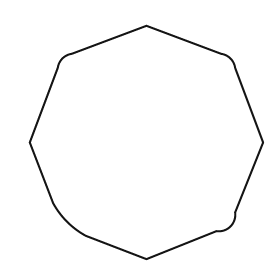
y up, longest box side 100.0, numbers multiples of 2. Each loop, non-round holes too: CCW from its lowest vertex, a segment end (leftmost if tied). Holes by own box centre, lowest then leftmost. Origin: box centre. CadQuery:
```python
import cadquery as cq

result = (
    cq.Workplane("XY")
    .moveTo(0.0, -50.0)
    .lineTo(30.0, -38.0)
    .threePointArc((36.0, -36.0), (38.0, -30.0))
    .lineTo(50.0, 0.0)
    .lineTo(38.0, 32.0)
    .threePointArc((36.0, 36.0), (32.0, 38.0))
    .lineTo(0.0, 50.0)
    .lineTo(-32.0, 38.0)
    .threePointArc((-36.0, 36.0), (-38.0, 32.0))
    .lineTo(-50.0, 0.0)
    .lineTo(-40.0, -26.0)
    .threePointArc((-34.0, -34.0), (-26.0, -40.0))
    .close()
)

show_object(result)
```